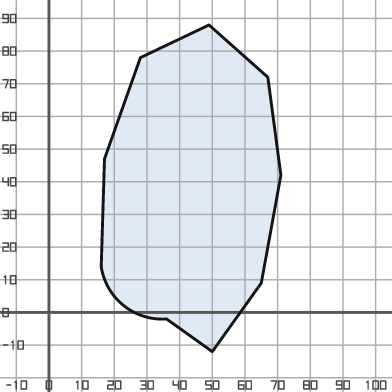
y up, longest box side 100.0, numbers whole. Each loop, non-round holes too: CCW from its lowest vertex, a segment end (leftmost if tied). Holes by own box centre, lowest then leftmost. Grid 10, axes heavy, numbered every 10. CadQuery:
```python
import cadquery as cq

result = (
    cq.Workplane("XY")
    .moveTo(50.0, -12.0)
    .lineTo(65.0, 9.0)
    .lineTo(71.0, 42.0)
    .lineTo(67.0, 72.0)
    .lineTo(49.0, 88.0)
    .lineTo(28.0, 78.0)
    .lineTo(17.0, 47.0)
    .lineTo(16.0, 14.0)
    .threePointArc((23.0, 2.0), (36.0, -2.0))
    .close()
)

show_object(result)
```